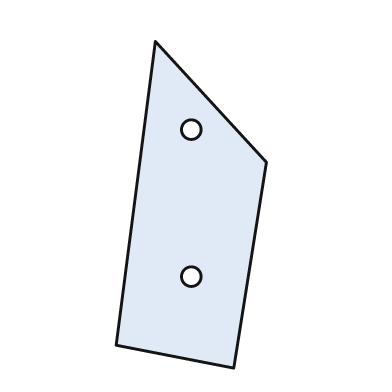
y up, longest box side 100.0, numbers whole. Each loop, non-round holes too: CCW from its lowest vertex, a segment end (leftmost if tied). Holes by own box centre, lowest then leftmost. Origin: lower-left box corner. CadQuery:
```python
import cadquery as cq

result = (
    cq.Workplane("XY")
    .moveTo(36.0, 0.0)
    .lineTo(46.0, 63.0)
    .lineTo(12.0, 100.0)
    .lineTo(0.0, 7.0)
    .close()
    .moveTo(23.0, 28.0)
    .circle(3.0)
    .moveTo(23.0, 73.0)
    .circle(3.0)
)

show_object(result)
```